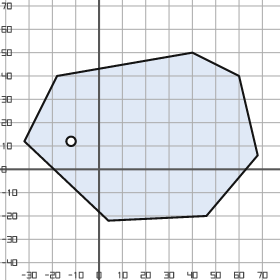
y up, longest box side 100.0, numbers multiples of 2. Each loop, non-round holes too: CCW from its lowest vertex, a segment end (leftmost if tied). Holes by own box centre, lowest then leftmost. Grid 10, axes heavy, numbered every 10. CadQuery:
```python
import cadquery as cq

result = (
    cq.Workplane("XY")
    .moveTo(4.0, -22.0)
    .lineTo(46.0, -20.0)
    .lineTo(68.0, 6.0)
    .lineTo(60.0, 40.0)
    .lineTo(40.0, 50.0)
    .lineTo(-18.0, 40.0)
    .lineTo(-32.0, 12.0)
    .close()
    .moveTo(-12.0, 12.0)
    .circle(2.0)
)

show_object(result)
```